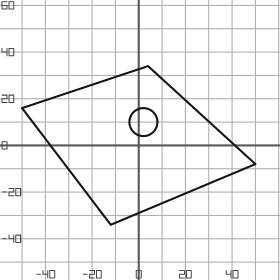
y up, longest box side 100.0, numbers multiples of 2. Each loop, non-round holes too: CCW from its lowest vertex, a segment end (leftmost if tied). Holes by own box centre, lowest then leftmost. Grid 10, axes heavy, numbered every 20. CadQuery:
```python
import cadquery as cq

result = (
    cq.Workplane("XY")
    .moveTo(-12.0, -34.0)
    .lineTo(50.0, -8.0)
    .lineTo(4.0, 34.0)
    .lineTo(-50.0, 16.0)
    .close()
    .moveTo(2.0, 10.0)
    .circle(6.0)
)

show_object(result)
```